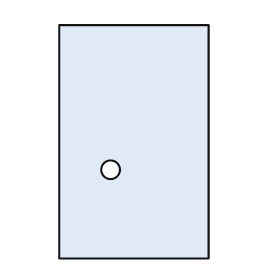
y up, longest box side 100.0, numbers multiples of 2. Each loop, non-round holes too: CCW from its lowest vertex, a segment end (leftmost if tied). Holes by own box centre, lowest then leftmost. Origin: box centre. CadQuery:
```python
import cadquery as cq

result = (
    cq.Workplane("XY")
    .moveTo(-32.0, -50.0)
    .lineTo(32.0, -50.0)
    .lineTo(32.0, 50.0)
    .lineTo(-32.0, 50.0)
    .close()
    .moveTo(-10.0, -12.0)
    .circle(4.0)
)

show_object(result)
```